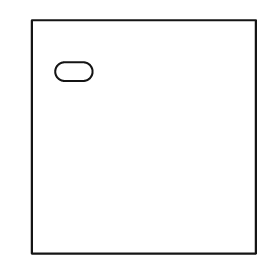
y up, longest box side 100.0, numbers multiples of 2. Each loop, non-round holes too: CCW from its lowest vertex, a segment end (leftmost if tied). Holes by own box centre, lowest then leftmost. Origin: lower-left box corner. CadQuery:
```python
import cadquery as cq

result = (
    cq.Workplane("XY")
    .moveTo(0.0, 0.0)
    .lineTo(96.0, 0.0)
    .lineTo(96.0, 100.0)
    .lineTo(0.0, 100.0)
    .close()
    .moveTo(14.0, 74.0)
    .lineTo(22.0, 74.0)
    .threePointArc((26.0, 78.0), (22.0, 82.0))
    .lineTo(14.0, 82.0)
    .threePointArc((10.0, 78.0), (14.0, 74.0))
    .close()
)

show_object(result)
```